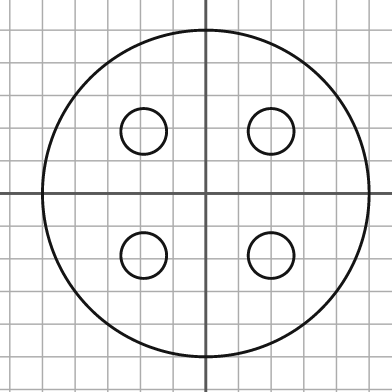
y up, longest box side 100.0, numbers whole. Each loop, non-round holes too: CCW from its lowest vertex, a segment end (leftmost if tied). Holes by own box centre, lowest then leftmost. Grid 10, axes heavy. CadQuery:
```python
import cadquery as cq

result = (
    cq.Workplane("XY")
    .moveTo(0.0, 0.0)
    .circle(50.0)
    .moveTo(-19.0, -19.0)
    .circle(7.0)
    .moveTo(20.0, -19.0)
    .circle(7.0)
    .moveTo(-19.0, 19.0)
    .circle(7.0)
    .moveTo(20.0, 19.0)
    .circle(7.0)
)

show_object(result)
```